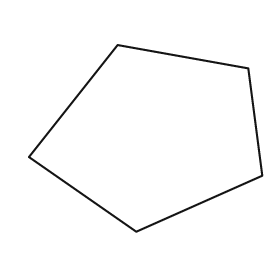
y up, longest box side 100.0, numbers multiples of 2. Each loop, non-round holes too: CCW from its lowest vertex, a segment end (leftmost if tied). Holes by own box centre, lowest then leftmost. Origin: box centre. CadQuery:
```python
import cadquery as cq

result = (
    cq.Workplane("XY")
    .moveTo(-4.0, -40.0)
    .lineTo(50.0, -16.0)
    .lineTo(44.0, 30.0)
    .lineTo(-12.0, 40.0)
    .lineTo(-50.0, -8.0)
    .close()
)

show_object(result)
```